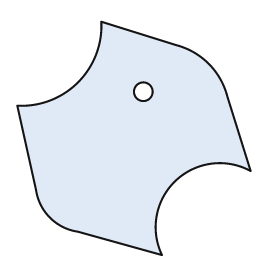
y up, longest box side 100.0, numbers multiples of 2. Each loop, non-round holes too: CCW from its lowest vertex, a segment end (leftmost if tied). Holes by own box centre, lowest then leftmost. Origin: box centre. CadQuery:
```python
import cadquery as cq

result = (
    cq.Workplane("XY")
    .moveTo(12.0, -50.0)
    .threePointArc((18.0, -18.0), (50.0, -14.0))
    .lineTo(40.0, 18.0)
    .threePointArc((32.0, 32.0), (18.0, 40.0))
    .lineTo(-14.0, 50.0)
    .threePointArc((-24.0, 24.0), (-50.0, 14.0))
    .lineTo(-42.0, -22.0)
    .threePointArc((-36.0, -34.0), (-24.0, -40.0))
    .close()
    .moveTo(4.0, 20.0)
    .circle(4.0)
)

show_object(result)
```